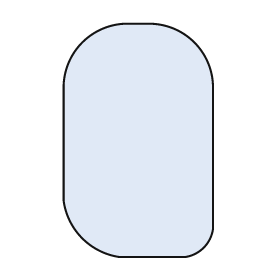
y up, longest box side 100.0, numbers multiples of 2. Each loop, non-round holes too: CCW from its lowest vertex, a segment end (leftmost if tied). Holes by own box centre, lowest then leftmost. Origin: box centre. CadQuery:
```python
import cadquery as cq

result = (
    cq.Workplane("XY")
    .moveTo(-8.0, -50.0)
    .lineTo(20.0, -50.0)
    .threePointArc((28.0, -46.0), (32.0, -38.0))
    .lineTo(32.0, 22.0)
    .threePointArc((24.0, 42.0), (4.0, 50.0))
    .lineTo(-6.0, 50.0)
    .threePointArc((-24.0, 42.0), (-32.0, 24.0))
    .lineTo(-32.0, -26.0)
    .threePointArc((-24.0, -42.0), (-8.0, -50.0))
    .close()
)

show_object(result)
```